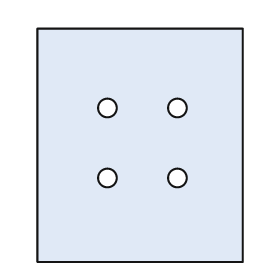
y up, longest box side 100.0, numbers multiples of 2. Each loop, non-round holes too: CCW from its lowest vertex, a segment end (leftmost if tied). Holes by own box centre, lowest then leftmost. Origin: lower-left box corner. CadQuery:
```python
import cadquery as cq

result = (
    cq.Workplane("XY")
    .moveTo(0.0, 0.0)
    .lineTo(88.0, 0.0)
    .lineTo(88.0, 100.0)
    .lineTo(0.0, 100.0)
    .close()
    .moveTo(30.0, 36.0)
    .circle(4.0)
    .moveTo(60.0, 36.0)
    .circle(4.0)
    .moveTo(30.0, 66.0)
    .circle(4.0)
    .moveTo(60.0, 66.0)
    .circle(4.0)
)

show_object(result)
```